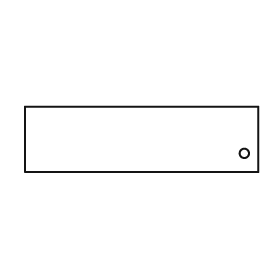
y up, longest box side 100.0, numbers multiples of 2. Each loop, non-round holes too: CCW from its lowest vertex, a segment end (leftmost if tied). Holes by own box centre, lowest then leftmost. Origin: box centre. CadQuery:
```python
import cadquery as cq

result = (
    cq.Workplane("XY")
    .moveTo(-50.0, -14.0)
    .lineTo(50.0, -14.0)
    .lineTo(50.0, 14.0)
    .lineTo(-50.0, 14.0)
    .close()
    .moveTo(44.0, -6.0)
    .circle(2.0)
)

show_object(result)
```